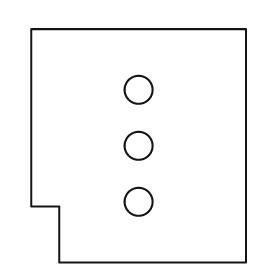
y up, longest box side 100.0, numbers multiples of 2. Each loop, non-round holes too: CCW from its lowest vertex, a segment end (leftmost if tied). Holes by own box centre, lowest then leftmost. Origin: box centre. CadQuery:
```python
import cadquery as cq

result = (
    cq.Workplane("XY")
    .moveTo(-34.0, -50.0)
    .lineTo(46.0, -50.0)
    .lineTo(46.0, 50.0)
    .lineTo(-46.0, 50.0)
    .lineTo(-46.0, -26.0)
    .lineTo(-34.0, -26.0)
    .close()
    .moveTo(0.0, -24.0)
    .circle(6.0)
    .moveTo(0.0, 0.0)
    .circle(6.0)
    .moveTo(0.0, 24.0)
    .circle(6.0)
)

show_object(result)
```